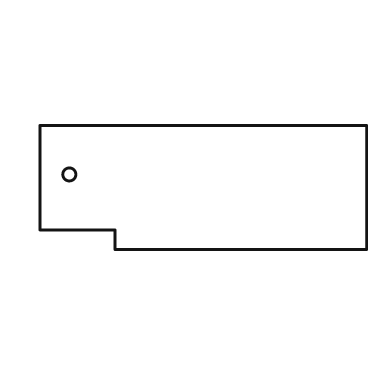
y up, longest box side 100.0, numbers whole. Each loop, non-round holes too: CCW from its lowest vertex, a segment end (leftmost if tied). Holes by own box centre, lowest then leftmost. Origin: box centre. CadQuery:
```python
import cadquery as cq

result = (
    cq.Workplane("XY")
    .moveTo(-27.0, -19.0)
    .lineTo(50.0, -19.0)
    .lineTo(50.0, 19.0)
    .lineTo(-50.0, 19.0)
    .lineTo(-50.0, -13.0)
    .lineTo(-27.0, -13.0)
    .close()
    .moveTo(-41.0, 4.0)
    .circle(2.0)
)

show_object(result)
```